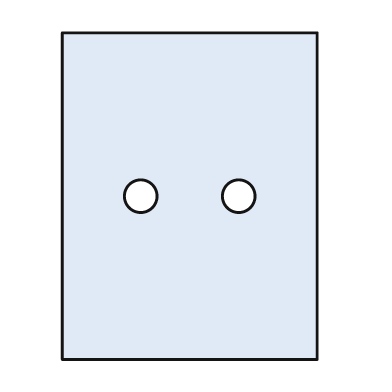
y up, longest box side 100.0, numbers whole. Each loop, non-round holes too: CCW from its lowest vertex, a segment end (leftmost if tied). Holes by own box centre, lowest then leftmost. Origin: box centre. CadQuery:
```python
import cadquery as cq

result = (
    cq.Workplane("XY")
    .moveTo(-39.0, -50.0)
    .lineTo(39.0, -50.0)
    .lineTo(39.0, 50.0)
    .lineTo(-39.0, 50.0)
    .close()
    .moveTo(-15.0, 0.0)
    .circle(5.0)
    .moveTo(15.0, 0.0)
    .circle(5.0)
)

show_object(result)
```